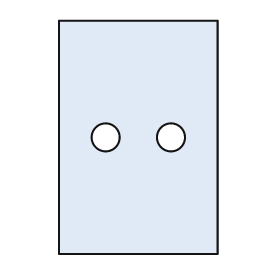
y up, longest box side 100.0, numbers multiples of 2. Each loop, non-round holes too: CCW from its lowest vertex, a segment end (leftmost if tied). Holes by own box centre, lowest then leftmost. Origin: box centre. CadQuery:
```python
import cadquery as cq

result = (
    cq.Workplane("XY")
    .moveTo(-34.0, -50.0)
    .lineTo(34.0, -50.0)
    .lineTo(34.0, 50.0)
    .lineTo(-34.0, 50.0)
    .close()
    .moveTo(-14.0, 0.0)
    .circle(6.0)
    .moveTo(14.0, 0.0)
    .circle(6.0)
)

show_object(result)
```